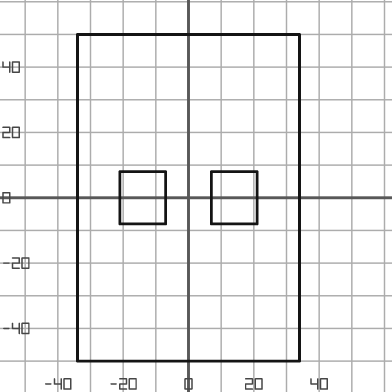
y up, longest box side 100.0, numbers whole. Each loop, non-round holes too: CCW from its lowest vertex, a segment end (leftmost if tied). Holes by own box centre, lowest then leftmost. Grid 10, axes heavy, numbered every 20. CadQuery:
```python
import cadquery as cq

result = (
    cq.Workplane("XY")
    .moveTo(-34.0, -50.0)
    .lineTo(34.0, -50.0)
    .lineTo(34.0, 50.0)
    .lineTo(-34.0, 50.0)
    .close()
    .moveTo(-21.0, -8.0)
    .lineTo(-7.0, -8.0)
    .lineTo(-7.0, 8.0)
    .lineTo(-21.0, 8.0)
    .close()
    .moveTo(7.0, -8.0)
    .lineTo(21.0, -8.0)
    .lineTo(21.0, 8.0)
    .lineTo(7.0, 8.0)
    .close()
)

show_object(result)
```